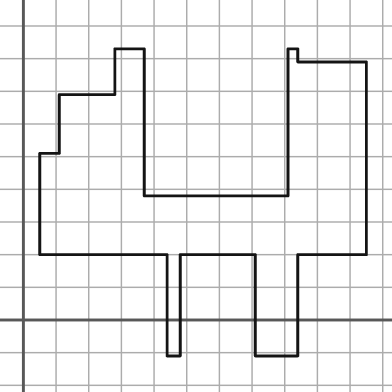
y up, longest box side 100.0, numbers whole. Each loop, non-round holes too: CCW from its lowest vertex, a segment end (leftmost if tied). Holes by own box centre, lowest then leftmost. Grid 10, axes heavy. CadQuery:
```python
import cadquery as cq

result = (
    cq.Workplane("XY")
    .moveTo(44.0, -11.0)
    .lineTo(48.0, -11.0)
    .lineTo(48.0, 20.0)
    .lineTo(71.0, 20.0)
    .lineTo(71.0, -11.0)
    .lineTo(84.0, -11.0)
    .lineTo(84.0, 20.0)
    .lineTo(105.0, 20.0)
    .lineTo(105.0, 79.0)
    .lineTo(84.0, 79.0)
    .lineTo(84.0, 83.0)
    .lineTo(81.0, 83.0)
    .lineTo(81.0, 38.0)
    .lineTo(37.0, 38.0)
    .lineTo(37.0, 83.0)
    .lineTo(28.0, 83.0)
    .lineTo(28.0, 69.0)
    .lineTo(11.0, 69.0)
    .lineTo(11.0, 51.0)
    .lineTo(5.0, 51.0)
    .lineTo(5.0, 20.0)
    .lineTo(44.0, 20.0)
    .close()
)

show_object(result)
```